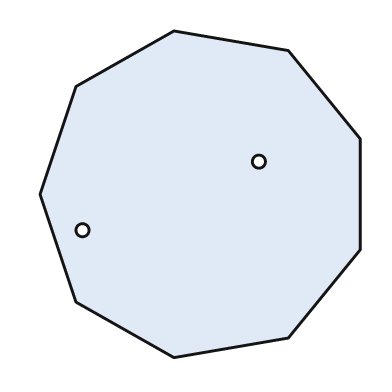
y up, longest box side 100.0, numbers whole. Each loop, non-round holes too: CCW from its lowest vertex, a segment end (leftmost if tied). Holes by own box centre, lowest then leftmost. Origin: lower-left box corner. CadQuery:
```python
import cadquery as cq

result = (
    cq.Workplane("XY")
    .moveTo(41.0, 0.0)
    .lineTo(76.0, 6.0)
    .lineTo(98.0, 33.0)
    .lineTo(98.0, 67.0)
    .lineTo(76.0, 94.0)
    .lineTo(41.0, 100.0)
    .lineTo(11.0, 83.0)
    .lineTo(0.0, 50.0)
    .lineTo(11.0, 17.0)
    .close()
    .moveTo(13.0, 39.0)
    .circle(2.0)
    .moveTo(67.0, 60.0)
    .circle(2.0)
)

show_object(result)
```